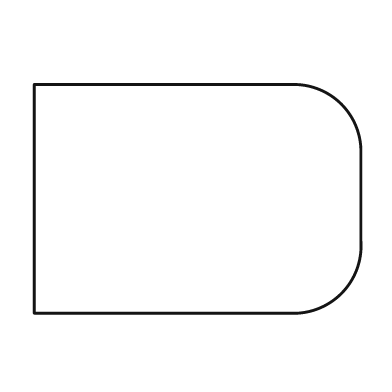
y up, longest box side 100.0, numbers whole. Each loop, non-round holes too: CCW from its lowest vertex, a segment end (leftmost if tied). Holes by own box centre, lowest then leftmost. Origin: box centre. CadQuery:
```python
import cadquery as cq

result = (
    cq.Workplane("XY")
    .moveTo(-50.0, -35.0)
    .lineTo(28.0, -35.0)
    .threePointArc((44.0, -29.0), (50.0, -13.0))
    .lineTo(50.0, 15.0)
    .threePointArc((44.0, 29.0), (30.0, 35.0))
    .lineTo(-50.0, 35.0)
    .close()
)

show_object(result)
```